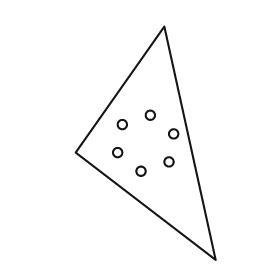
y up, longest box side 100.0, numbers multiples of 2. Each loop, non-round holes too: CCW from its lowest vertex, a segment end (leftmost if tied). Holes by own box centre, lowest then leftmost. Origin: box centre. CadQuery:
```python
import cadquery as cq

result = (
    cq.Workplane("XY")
    .moveTo(30.0, -50.0)
    .lineTo(8.0, 50.0)
    .lineTo(-30.0, -4.0)
    .close()
    .moveTo(-2.0, -12.0)
    .circle(2.0)
    .moveTo(10.0, -8.0)
    .circle(2.0)
    .moveTo(-12.0, -4.0)
    .circle(2.0)
    .moveTo(12.0, 4.0)
    .circle(2.0)
    .moveTo(-10.0, 8.0)
    .circle(2.0)
    .moveTo(2.0, 12.0)
    .circle(2.0)
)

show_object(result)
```